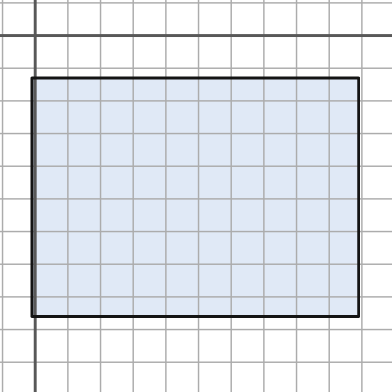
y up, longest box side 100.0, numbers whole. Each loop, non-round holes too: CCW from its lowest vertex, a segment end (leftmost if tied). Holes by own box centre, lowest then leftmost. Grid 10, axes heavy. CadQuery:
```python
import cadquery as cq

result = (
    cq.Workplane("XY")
    .moveTo(-1.0, -86.0)
    .lineTo(99.0, -86.0)
    .lineTo(99.0, -13.0)
    .lineTo(-1.0, -13.0)
    .close()
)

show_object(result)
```